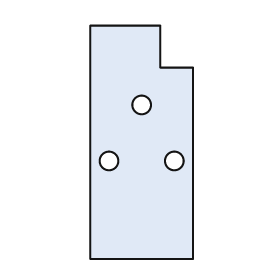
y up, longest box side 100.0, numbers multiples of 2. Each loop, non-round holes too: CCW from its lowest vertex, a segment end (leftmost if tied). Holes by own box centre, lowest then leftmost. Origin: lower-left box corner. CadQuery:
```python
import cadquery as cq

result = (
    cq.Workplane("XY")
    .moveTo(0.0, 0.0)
    .lineTo(44.0, 0.0)
    .lineTo(44.0, 82.0)
    .lineTo(30.0, 82.0)
    .lineTo(30.0, 100.0)
    .lineTo(0.0, 100.0)
    .close()
    .moveTo(8.0, 42.0)
    .circle(4.0)
    .moveTo(36.0, 42.0)
    .circle(4.0)
    .moveTo(22.0, 66.0)
    .circle(4.0)
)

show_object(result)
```